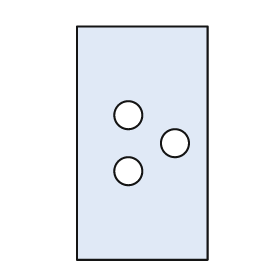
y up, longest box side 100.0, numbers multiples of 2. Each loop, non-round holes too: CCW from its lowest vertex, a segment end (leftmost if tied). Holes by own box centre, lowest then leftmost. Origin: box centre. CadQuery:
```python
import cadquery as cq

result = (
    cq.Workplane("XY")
    .moveTo(-28.0, -50.0)
    .lineTo(28.0, -50.0)
    .lineTo(28.0, 50.0)
    .lineTo(-28.0, 50.0)
    .close()
    .moveTo(-6.0, -12.0)
    .circle(6.0)
    .moveTo(14.0, 0.0)
    .circle(6.0)
    .moveTo(-6.0, 12.0)
    .circle(6.0)
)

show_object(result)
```